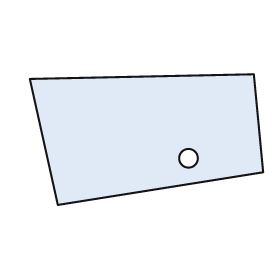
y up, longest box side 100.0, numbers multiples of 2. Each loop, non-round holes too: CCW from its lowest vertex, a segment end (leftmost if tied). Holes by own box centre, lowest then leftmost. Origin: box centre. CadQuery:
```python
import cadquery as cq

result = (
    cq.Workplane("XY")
    .moveTo(-38.0, -28.0)
    .lineTo(50.0, -14.0)
    .lineTo(46.0, 28.0)
    .lineTo(-50.0, 26.0)
    .close()
    .moveTo(18.0, -8.0)
    .circle(4.0)
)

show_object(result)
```